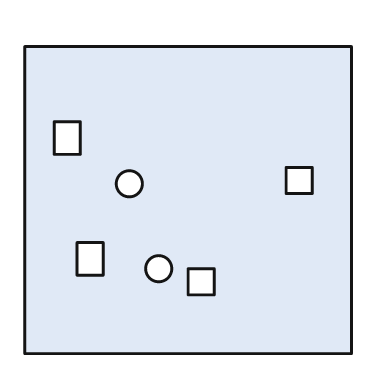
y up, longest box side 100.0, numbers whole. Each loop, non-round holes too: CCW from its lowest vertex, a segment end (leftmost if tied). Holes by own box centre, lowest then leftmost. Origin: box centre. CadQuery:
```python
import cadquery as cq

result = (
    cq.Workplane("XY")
    .moveTo(-50.0, -47.0)
    .lineTo(50.0, -47.0)
    .lineTo(50.0, 47.0)
    .lineTo(-50.0, 47.0)
    .close()
    .moveTo(0.0, -29.0)
    .lineTo(8.0, -29.0)
    .lineTo(8.0, -21.0)
    .lineTo(0.0, -21.0)
    .close()
    .moveTo(-9.0, -21.0)
    .circle(4.0)
    .moveTo(-34.0, -23.0)
    .lineTo(-26.0, -23.0)
    .lineTo(-26.0, -13.0)
    .lineTo(-34.0, -13.0)
    .close()
    .moveTo(-18.0, 5.0)
    .circle(4.0)
    .moveTo(30.0, 2.0)
    .lineTo(38.0, 2.0)
    .lineTo(38.0, 10.0)
    .lineTo(30.0, 10.0)
    .close()
    .moveTo(-41.0, 14.0)
    .lineTo(-33.0, 14.0)
    .lineTo(-33.0, 24.0)
    .lineTo(-41.0, 24.0)
    .close()
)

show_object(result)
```